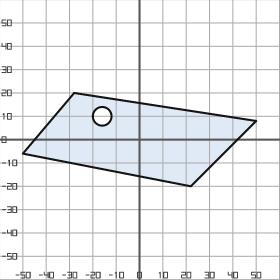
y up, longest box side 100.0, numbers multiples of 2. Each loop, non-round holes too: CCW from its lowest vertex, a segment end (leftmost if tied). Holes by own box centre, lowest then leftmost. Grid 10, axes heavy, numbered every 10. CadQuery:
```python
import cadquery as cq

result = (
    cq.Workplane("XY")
    .moveTo(22.0, -20.0)
    .lineTo(50.0, 8.0)
    .lineTo(-28.0, 20.0)
    .lineTo(-50.0, -6.0)
    .close()
    .moveTo(-16.0, 10.0)
    .circle(4.0)
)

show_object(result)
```